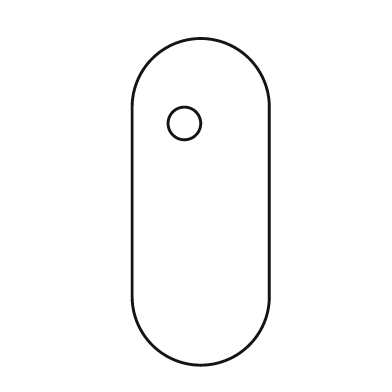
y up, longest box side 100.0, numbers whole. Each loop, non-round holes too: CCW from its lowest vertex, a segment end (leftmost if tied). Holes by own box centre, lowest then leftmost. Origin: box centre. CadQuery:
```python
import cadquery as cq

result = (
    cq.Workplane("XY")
    .moveTo(-21.0, -29.0)
    .threePointArc((0.0, -50.0), (21.0, -29.0))
    .lineTo(21.0, 29.0)
    .threePointArc((0.0, 50.0), (-21.0, 29.0))
    .close()
    .moveTo(-5.0, 24.0)
    .circle(5.0)
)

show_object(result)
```